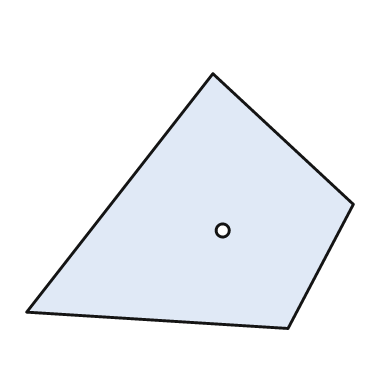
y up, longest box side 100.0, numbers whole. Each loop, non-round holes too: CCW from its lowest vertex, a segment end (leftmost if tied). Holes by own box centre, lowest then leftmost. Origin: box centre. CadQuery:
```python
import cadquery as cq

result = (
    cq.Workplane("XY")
    .moveTo(30.0, -39.0)
    .lineTo(50.0, -1.0)
    .lineTo(7.0, 39.0)
    .lineTo(-50.0, -34.0)
    .close()
    .moveTo(10.0, -9.0)
    .circle(2.0)
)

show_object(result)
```